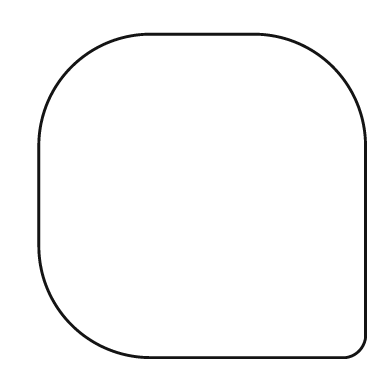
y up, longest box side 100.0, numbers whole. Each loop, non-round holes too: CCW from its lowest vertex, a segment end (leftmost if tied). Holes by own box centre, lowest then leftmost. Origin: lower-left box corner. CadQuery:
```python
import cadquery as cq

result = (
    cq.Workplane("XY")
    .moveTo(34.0, 0.0)
    .lineTo(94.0, 0.0)
    .threePointArc((98.0, 2.0), (100.0, 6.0))
    .lineTo(100.0, 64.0)
    .threePointArc((90.0, 89.0), (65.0, 99.0))
    .lineTo(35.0, 99.0)
    .threePointArc((10.0, 89.0), (0.0, 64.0))
    .lineTo(0.0, 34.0)
    .threePointArc((10.0, 10.0), (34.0, 0.0))
    .close()
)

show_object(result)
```